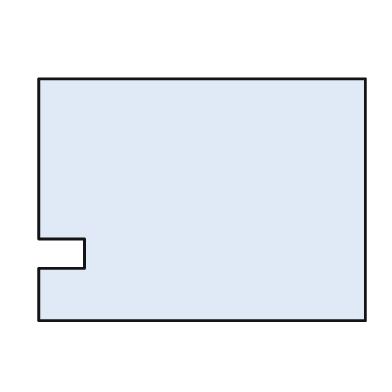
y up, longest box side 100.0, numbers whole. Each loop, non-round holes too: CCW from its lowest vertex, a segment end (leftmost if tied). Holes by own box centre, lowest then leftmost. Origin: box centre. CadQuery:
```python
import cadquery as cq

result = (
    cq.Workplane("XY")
    .moveTo(-50.0, -37.0)
    .lineTo(50.0, -37.0)
    .lineTo(50.0, 37.0)
    .lineTo(-50.0, 37.0)
    .lineTo(-50.0, -12.0)
    .lineTo(-36.0, -12.0)
    .lineTo(-36.0, -21.0)
    .lineTo(-50.0, -21.0)
    .close()
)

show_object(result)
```